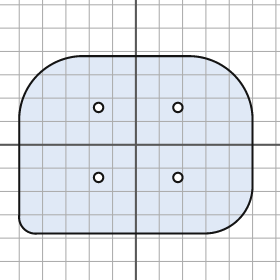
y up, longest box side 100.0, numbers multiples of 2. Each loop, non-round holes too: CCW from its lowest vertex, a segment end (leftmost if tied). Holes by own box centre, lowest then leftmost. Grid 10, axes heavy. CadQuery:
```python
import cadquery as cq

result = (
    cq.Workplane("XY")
    .moveTo(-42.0, -38.0)
    .lineTo(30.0, -38.0)
    .threePointArc((44.0, -32.0), (50.0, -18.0))
    .lineTo(50.0, 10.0)
    .threePointArc((42.0, 30.0), (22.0, 38.0))
    .lineTo(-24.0, 38.0)
    .threePointArc((-42.0, 30.0), (-50.0, 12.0))
    .lineTo(-50.0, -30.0)
    .threePointArc((-48.0, -36.0), (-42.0, -38.0))
    .close()
    .moveTo(-16.0, -14.0)
    .circle(2.0)
    .moveTo(18.0, -14.0)
    .circle(2.0)
    .moveTo(-16.0, 16.0)
    .circle(2.0)
    .moveTo(18.0, 16.0)
    .circle(2.0)
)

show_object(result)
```